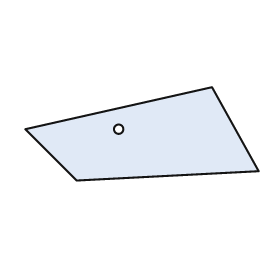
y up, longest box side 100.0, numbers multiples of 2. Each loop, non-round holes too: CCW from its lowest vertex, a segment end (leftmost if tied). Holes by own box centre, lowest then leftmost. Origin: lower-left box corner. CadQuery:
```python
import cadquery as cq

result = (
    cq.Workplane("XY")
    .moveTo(22.0, 0.0)
    .lineTo(100.0, 4.0)
    .lineTo(80.0, 40.0)
    .lineTo(0.0, 22.0)
    .close()
    .moveTo(40.0, 22.0)
    .circle(2.0)
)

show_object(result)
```